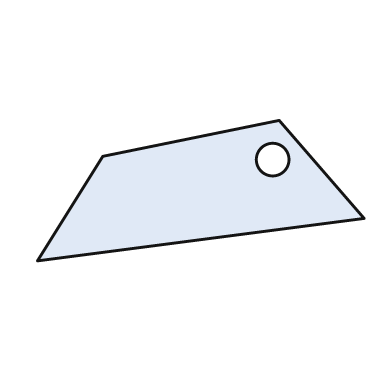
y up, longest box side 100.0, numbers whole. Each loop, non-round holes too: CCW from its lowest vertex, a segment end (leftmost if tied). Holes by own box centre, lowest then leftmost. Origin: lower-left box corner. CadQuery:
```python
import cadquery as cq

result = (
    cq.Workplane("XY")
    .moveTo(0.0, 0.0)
    .lineTo(100.0, 13.0)
    .lineTo(74.0, 43.0)
    .lineTo(20.0, 32.0)
    .close()
    .moveTo(72.0, 31.0)
    .circle(5.0)
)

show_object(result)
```